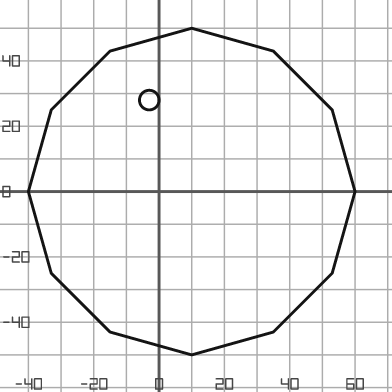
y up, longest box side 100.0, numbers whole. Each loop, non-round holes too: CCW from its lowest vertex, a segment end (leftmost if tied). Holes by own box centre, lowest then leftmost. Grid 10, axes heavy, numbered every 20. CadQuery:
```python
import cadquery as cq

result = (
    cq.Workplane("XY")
    .moveTo(10.0, -50.0)
    .lineTo(35.0, -43.0)
    .lineTo(53.0, -25.0)
    .lineTo(60.0, 0.0)
    .lineTo(53.0, 25.0)
    .lineTo(35.0, 43.0)
    .lineTo(10.0, 50.0)
    .lineTo(-15.0, 43.0)
    .lineTo(-33.0, 25.0)
    .lineTo(-40.0, 0.0)
    .lineTo(-33.0, -25.0)
    .lineTo(-15.0, -43.0)
    .close()
    .moveTo(-3.0, 28.0)
    .circle(3.0)
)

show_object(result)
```